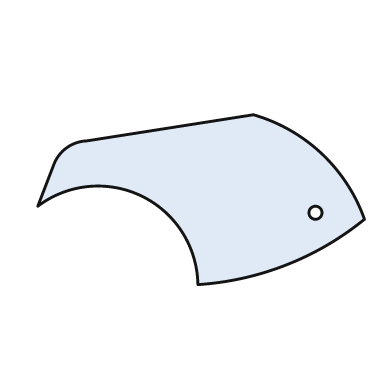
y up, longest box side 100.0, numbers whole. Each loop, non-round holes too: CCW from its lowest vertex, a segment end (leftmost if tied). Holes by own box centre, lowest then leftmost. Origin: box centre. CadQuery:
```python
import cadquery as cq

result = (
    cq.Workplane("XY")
    .moveTo(-1.0, -26.0)
    .threePointArc((26.0, -20.0), (50.0, -6.0))
    .threePointArc((37.0, 14.0), (16.0, 26.0))
    .lineTo(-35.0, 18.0)
    .threePointArc((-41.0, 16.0), (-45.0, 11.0))
    .lineTo(-50.0, -2.0)
    .threePointArc((-18.0, 1.0), (-1.0, -26.0))
    .close()
    .moveTo(35.0, -4.0)
    .circle(2.0)
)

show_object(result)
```